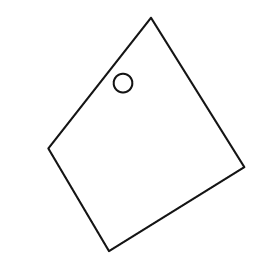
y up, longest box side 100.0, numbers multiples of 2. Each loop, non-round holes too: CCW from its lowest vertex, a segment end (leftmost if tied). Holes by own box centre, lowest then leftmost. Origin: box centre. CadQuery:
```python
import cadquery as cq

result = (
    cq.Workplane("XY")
    .moveTo(-16.0, -50.0)
    .lineTo(42.0, -14.0)
    .lineTo(2.0, 50.0)
    .lineTo(-42.0, -6.0)
    .close()
    .moveTo(-10.0, 22.0)
    .circle(4.0)
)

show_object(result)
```